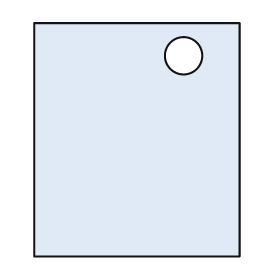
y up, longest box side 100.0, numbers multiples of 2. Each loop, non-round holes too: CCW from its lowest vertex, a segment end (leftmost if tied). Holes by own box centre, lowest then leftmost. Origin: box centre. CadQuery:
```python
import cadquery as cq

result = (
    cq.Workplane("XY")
    .moveTo(-44.0, -50.0)
    .lineTo(44.0, -50.0)
    .lineTo(44.0, 50.0)
    .lineTo(-44.0, 50.0)
    .close()
    .moveTo(20.0, 36.0)
    .circle(8.0)
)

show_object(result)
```